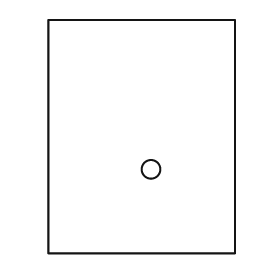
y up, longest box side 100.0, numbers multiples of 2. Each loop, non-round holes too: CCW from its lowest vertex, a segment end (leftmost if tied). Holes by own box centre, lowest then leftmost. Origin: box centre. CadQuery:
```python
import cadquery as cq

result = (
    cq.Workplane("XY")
    .moveTo(-40.0, -50.0)
    .lineTo(40.0, -50.0)
    .lineTo(40.0, 50.0)
    .lineTo(-40.0, 50.0)
    .close()
    .moveTo(4.0, -14.0)
    .circle(4.0)
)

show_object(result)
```